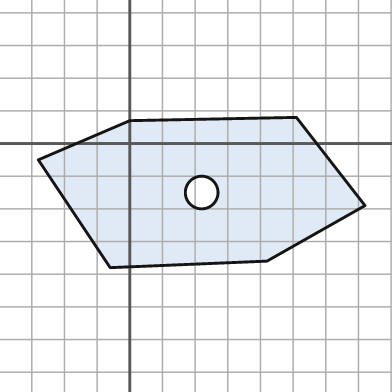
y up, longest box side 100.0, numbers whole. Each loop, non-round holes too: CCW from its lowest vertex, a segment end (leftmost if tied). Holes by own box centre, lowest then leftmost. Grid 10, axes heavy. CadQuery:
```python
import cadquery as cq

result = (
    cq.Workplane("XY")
    .moveTo(-6.0, -38.0)
    .lineTo(42.0, -36.0)
    .lineTo(72.0, -19.0)
    .lineTo(51.0, 8.0)
    .lineTo(0.0, 7.0)
    .lineTo(-28.0, -5.0)
    .close()
    .moveTo(22.0, -15.0)
    .circle(5.0)
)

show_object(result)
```